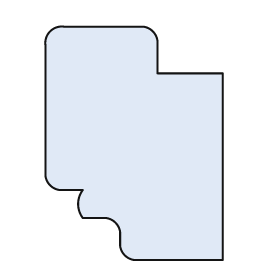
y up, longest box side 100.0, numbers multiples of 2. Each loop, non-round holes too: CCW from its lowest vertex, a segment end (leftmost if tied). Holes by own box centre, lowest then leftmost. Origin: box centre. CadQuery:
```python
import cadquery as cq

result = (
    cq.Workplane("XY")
    .moveTo(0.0, -50.0)
    .lineTo(38.0, -50.0)
    .lineTo(38.0, 30.0)
    .lineTo(10.0, 30.0)
    .lineTo(10.0, 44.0)
    .threePointArc((8.0, 48.0), (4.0, 50.0))
    .lineTo(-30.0, 50.0)
    .threePointArc((-36.0, 48.0), (-38.0, 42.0))
    .lineTo(-38.0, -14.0)
    .threePointArc((-36.0, -18.0), (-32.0, -20.0))
    .lineTo(-22.0, -20.0)
    .threePointArc((-24.0, -26.0), (-22.0, -32.0))
    .lineTo(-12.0, -32.0)
    .threePointArc((-8.0, -34.0), (-6.0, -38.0))
    .lineTo(-6.0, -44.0)
    .threePointArc((-4.0, -48.0), (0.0, -50.0))
    .close()
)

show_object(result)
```